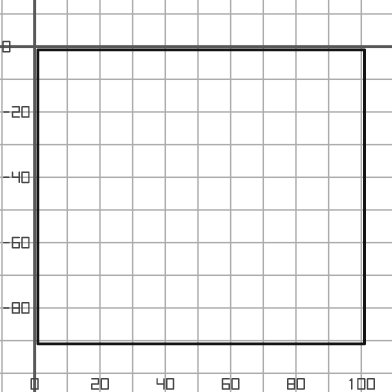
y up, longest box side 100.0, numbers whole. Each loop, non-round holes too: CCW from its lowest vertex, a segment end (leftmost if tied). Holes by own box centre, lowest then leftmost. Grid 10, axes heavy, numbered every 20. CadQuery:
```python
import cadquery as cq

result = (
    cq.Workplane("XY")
    .moveTo(1.0, -91.0)
    .lineTo(101.0, -91.0)
    .lineTo(101.0, -1.0)
    .lineTo(1.0, -1.0)
    .close()
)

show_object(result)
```